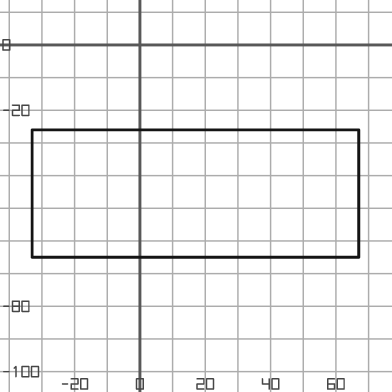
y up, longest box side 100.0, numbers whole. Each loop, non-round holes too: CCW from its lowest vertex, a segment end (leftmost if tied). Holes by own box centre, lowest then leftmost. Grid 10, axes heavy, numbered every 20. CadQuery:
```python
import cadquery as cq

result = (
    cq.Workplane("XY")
    .moveTo(-33.0, -65.0)
    .lineTo(67.0, -65.0)
    .lineTo(67.0, -26.0)
    .lineTo(-33.0, -26.0)
    .close()
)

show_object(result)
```